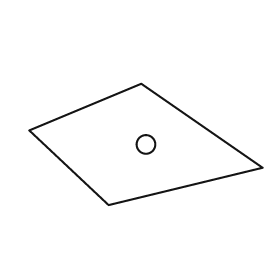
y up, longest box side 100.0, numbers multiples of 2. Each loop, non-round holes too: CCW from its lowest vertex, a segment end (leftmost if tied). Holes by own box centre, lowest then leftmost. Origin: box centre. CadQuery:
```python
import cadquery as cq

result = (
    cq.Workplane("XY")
    .moveTo(-16.0, -26.0)
    .lineTo(50.0, -10.0)
    .lineTo(-2.0, 26.0)
    .lineTo(-50.0, 6.0)
    .close()
    .moveTo(0.0, 0.0)
    .circle(4.0)
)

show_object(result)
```